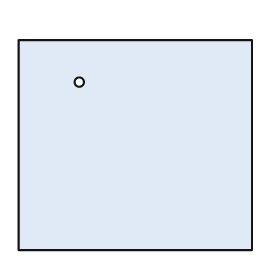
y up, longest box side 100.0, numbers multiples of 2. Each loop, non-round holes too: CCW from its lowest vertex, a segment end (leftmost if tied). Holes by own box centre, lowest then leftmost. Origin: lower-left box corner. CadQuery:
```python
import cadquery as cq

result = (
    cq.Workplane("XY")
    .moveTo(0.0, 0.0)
    .lineTo(100.0, 0.0)
    .lineTo(100.0, 90.0)
    .lineTo(0.0, 90.0)
    .close()
    .moveTo(26.0, 72.0)
    .circle(2.0)
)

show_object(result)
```